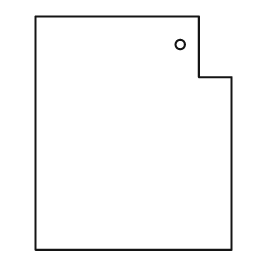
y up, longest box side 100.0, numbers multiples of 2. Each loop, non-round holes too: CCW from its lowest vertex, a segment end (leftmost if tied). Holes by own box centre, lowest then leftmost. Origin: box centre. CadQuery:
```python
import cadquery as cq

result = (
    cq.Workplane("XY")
    .moveTo(-42.0, -50.0)
    .lineTo(42.0, -50.0)
    .lineTo(42.0, 24.0)
    .lineTo(28.0, 24.0)
    .lineTo(28.0, 50.0)
    .lineTo(-42.0, 50.0)
    .close()
    .moveTo(20.0, 38.0)
    .circle(2.0)
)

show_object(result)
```